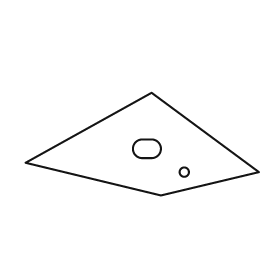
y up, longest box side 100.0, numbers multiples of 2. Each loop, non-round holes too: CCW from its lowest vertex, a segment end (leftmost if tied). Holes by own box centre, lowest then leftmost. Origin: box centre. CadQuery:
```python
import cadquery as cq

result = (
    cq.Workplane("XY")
    .moveTo(8.0, -22.0)
    .lineTo(50.0, -12.0)
    .lineTo(4.0, 22.0)
    .lineTo(-50.0, -8.0)
    .close()
    .moveTo(18.0, -12.0)
    .circle(2.0)
    .moveTo(0.0, -6.0)
    .lineTo(4.0, -6.0)
    .threePointArc((8.0, -2.0), (4.0, 2.0))
    .lineTo(0.0, 2.0)
    .threePointArc((-4.0, -2.0), (0.0, -6.0))
    .close()
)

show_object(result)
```